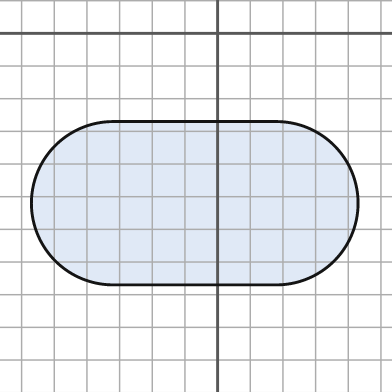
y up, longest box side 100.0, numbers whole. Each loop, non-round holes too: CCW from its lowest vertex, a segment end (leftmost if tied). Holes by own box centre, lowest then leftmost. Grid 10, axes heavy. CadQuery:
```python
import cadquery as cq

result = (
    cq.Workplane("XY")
    .moveTo(-32.0, -77.0)
    .lineTo(18.0, -77.0)
    .threePointArc((43.0, -52.0), (18.0, -27.0))
    .lineTo(-32.0, -27.0)
    .threePointArc((-57.0, -52.0), (-32.0, -77.0))
    .close()
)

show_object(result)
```